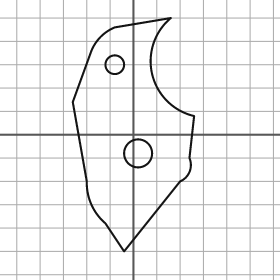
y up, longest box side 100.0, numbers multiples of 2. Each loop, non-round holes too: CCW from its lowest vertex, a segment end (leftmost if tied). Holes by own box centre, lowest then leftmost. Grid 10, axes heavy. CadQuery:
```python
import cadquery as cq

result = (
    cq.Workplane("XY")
    .moveTo(-4.0, -50.0)
    .lineTo(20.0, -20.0)
    .threePointArc((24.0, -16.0), (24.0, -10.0))
    .lineTo(26.0, 8.0)
    .threePointArc((8.0, 26.0), (16.0, 50.0))
    .lineTo(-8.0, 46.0)
    .threePointArc((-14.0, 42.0), (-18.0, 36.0))
    .lineTo(-26.0, 14.0)
    .lineTo(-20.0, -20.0)
    .threePointArc((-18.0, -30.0), (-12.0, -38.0))
    .close()
    .moveTo(2.0, -8.0)
    .circle(6.0)
    .moveTo(-8.0, 30.0)
    .circle(4.0)
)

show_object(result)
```